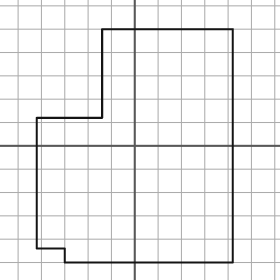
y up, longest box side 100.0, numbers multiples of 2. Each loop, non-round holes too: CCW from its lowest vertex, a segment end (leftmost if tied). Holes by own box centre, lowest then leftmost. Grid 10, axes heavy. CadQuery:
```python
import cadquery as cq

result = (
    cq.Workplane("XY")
    .moveTo(-30.0, -50.0)
    .lineTo(42.0, -50.0)
    .lineTo(42.0, 50.0)
    .lineTo(-14.0, 50.0)
    .lineTo(-14.0, 12.0)
    .lineTo(-42.0, 12.0)
    .lineTo(-42.0, -44.0)
    .lineTo(-30.0, -44.0)
    .close()
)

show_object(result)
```